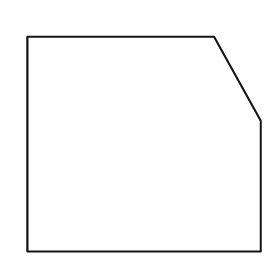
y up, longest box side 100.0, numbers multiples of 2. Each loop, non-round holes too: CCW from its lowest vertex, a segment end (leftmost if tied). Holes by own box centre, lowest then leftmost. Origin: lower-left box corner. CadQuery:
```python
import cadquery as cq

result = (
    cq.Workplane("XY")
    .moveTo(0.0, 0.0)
    .lineTo(100.0, 0.0)
    .lineTo(100.0, 56.0)
    .lineTo(80.0, 92.0)
    .lineTo(0.0, 92.0)
    .close()
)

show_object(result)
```